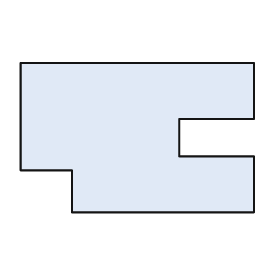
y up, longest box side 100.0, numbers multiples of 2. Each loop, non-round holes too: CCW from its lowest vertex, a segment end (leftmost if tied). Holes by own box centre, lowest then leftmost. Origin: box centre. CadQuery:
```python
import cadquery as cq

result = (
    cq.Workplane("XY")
    .moveTo(-28.0, -32.0)
    .lineTo(50.0, -32.0)
    .lineTo(50.0, -8.0)
    .lineTo(18.0, -8.0)
    .lineTo(18.0, 8.0)
    .lineTo(50.0, 8.0)
    .lineTo(50.0, 32.0)
    .lineTo(-50.0, 32.0)
    .lineTo(-50.0, -14.0)
    .lineTo(-28.0, -14.0)
    .close()
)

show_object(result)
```